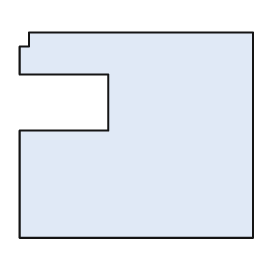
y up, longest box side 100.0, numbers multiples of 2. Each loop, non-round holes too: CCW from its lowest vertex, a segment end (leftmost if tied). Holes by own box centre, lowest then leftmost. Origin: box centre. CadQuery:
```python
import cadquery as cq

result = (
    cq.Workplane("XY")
    .moveTo(-50.0, -44.0)
    .lineTo(50.0, -44.0)
    .lineTo(50.0, 44.0)
    .lineTo(-46.0, 44.0)
    .lineTo(-46.0, 38.0)
    .lineTo(-50.0, 38.0)
    .lineTo(-50.0, 26.0)
    .lineTo(-12.0, 26.0)
    .lineTo(-12.0, 2.0)
    .lineTo(-50.0, 2.0)
    .close()
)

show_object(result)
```